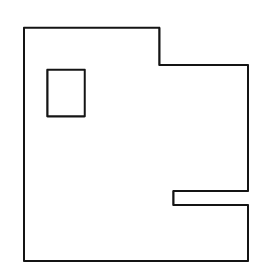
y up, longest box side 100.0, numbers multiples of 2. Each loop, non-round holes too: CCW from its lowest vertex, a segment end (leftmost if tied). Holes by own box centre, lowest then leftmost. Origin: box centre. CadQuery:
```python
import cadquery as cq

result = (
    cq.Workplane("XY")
    .moveTo(-48.0, -50.0)
    .lineTo(48.0, -50.0)
    .lineTo(48.0, -26.0)
    .lineTo(16.0, -26.0)
    .lineTo(16.0, -20.0)
    .lineTo(48.0, -20.0)
    .lineTo(48.0, 34.0)
    .lineTo(10.0, 34.0)
    .lineTo(10.0, 50.0)
    .lineTo(-48.0, 50.0)
    .close()
    .moveTo(-38.0, 12.0)
    .lineTo(-22.0, 12.0)
    .lineTo(-22.0, 32.0)
    .lineTo(-38.0, 32.0)
    .close()
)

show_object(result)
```